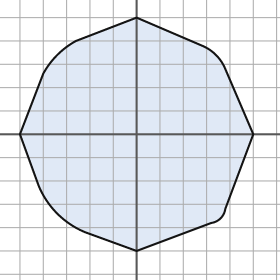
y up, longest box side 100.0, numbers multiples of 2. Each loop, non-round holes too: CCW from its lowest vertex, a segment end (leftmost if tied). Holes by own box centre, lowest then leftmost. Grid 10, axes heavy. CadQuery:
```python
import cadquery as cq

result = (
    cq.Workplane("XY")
    .moveTo(0.0, -50.0)
    .lineTo(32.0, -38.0)
    .threePointArc((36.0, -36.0), (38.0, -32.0))
    .lineTo(50.0, 0.0)
    .lineTo(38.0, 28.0)
    .threePointArc((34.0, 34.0), (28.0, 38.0))
    .lineTo(0.0, 50.0)
    .lineTo(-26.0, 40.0)
    .threePointArc((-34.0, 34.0), (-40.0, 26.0))
    .lineTo(-50.0, 0.0)
    .lineTo(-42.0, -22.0)
    .threePointArc((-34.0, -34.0), (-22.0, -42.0))
    .close()
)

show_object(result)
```